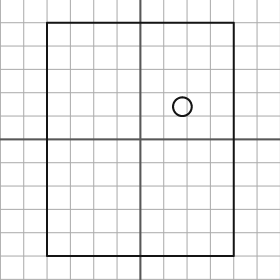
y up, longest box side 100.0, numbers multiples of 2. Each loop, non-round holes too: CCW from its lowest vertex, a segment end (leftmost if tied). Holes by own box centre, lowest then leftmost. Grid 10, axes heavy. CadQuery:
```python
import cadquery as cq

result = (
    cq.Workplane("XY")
    .moveTo(-40.0, -50.0)
    .lineTo(40.0, -50.0)
    .lineTo(40.0, 50.0)
    .lineTo(-40.0, 50.0)
    .close()
    .moveTo(18.0, 14.0)
    .circle(4.0)
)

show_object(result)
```